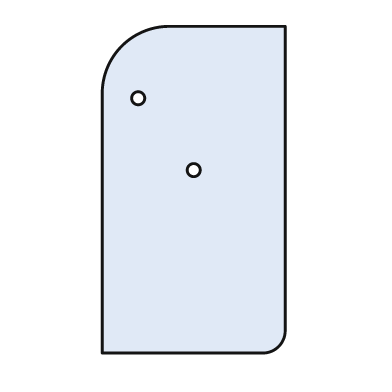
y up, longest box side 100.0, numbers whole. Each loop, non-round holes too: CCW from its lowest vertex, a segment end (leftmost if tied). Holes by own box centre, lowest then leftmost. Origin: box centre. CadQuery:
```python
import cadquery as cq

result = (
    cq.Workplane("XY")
    .moveTo(-28.0, -50.0)
    .lineTo(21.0, -50.0)
    .threePointArc((26.0, -48.0), (28.0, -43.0))
    .lineTo(28.0, 50.0)
    .lineTo(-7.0, 50.0)
    .threePointArc((-22.0, 44.0), (-28.0, 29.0))
    .close()
    .moveTo(0.0, 6.0)
    .circle(2.0)
    .moveTo(-17.0, 28.0)
    .circle(2.0)
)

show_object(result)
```